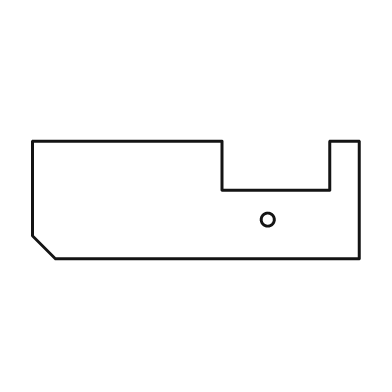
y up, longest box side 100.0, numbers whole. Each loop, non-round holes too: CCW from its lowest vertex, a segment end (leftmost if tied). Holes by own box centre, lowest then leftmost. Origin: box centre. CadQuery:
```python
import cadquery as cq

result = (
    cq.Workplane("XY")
    .moveTo(-43.0, -18.0)
    .lineTo(50.0, -18.0)
    .lineTo(50.0, 18.0)
    .lineTo(41.0, 18.0)
    .lineTo(41.0, 3.0)
    .lineTo(8.0, 3.0)
    .lineTo(8.0, 18.0)
    .lineTo(-50.0, 18.0)
    .lineTo(-50.0, -11.0)
    .close()
    .moveTo(22.0, -6.0)
    .circle(2.0)
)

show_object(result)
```